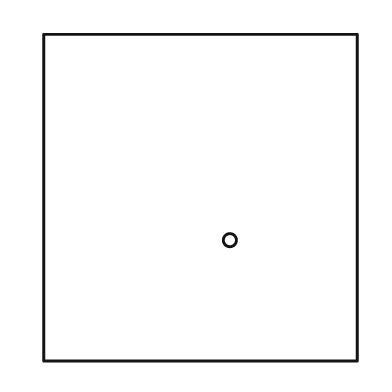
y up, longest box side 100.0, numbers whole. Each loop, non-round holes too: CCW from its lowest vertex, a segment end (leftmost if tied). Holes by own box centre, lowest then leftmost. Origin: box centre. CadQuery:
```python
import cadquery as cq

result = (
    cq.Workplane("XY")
    .moveTo(-48.0, -50.0)
    .lineTo(48.0, -50.0)
    .lineTo(48.0, 50.0)
    .lineTo(-48.0, 50.0)
    .close()
    .moveTo(9.0, -13.0)
    .circle(2.0)
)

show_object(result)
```